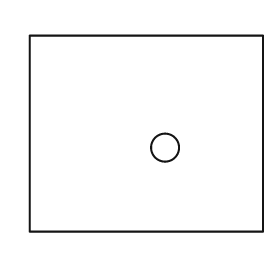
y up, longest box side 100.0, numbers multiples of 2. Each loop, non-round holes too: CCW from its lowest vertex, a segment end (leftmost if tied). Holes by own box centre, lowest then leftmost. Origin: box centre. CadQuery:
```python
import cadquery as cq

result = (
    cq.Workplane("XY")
    .moveTo(-50.0, -42.0)
    .lineTo(50.0, -42.0)
    .lineTo(50.0, 42.0)
    .lineTo(-50.0, 42.0)
    .close()
    .moveTo(8.0, -6.0)
    .circle(6.0)
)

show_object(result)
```